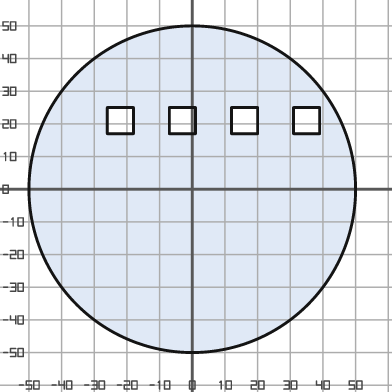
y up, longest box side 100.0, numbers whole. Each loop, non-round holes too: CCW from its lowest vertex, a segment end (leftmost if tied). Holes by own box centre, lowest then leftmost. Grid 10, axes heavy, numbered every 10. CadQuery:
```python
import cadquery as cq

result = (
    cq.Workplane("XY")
    .moveTo(0.0, 0.0)
    .circle(50.0)
    .moveTo(-26.0, 17.0)
    .lineTo(-18.0, 17.0)
    .lineTo(-18.0, 25.0)
    .lineTo(-26.0, 25.0)
    .close()
    .moveTo(-7.0, 17.0)
    .lineTo(1.0, 17.0)
    .lineTo(1.0, 25.0)
    .lineTo(-7.0, 25.0)
    .close()
    .moveTo(12.0, 17.0)
    .lineTo(20.0, 17.0)
    .lineTo(20.0, 25.0)
    .lineTo(12.0, 25.0)
    .close()
    .moveTo(31.0, 17.0)
    .lineTo(39.0, 17.0)
    .lineTo(39.0, 25.0)
    .lineTo(31.0, 25.0)
    .close()
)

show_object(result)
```